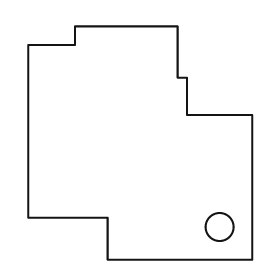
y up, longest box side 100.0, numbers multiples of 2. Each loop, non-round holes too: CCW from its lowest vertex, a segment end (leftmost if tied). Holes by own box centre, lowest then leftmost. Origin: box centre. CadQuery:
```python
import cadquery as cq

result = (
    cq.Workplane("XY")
    .moveTo(-14.0, -50.0)
    .lineTo(48.0, -50.0)
    .lineTo(48.0, 12.0)
    .lineTo(20.0, 12.0)
    .lineTo(20.0, 28.0)
    .lineTo(16.0, 28.0)
    .lineTo(16.0, 50.0)
    .lineTo(-28.0, 50.0)
    .lineTo(-28.0, 42.0)
    .lineTo(-48.0, 42.0)
    .lineTo(-48.0, -32.0)
    .lineTo(-14.0, -32.0)
    .close()
    .moveTo(34.0, -36.0)
    .circle(6.0)
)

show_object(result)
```